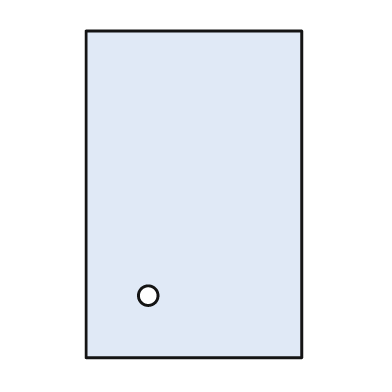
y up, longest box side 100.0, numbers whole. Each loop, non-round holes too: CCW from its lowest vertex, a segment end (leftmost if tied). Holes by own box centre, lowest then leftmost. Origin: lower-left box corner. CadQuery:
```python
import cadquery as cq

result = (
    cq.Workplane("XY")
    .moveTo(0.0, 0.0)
    .lineTo(66.0, 0.0)
    .lineTo(66.0, 100.0)
    .lineTo(0.0, 100.0)
    .close()
    .moveTo(19.0, 19.0)
    .circle(3.0)
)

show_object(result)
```